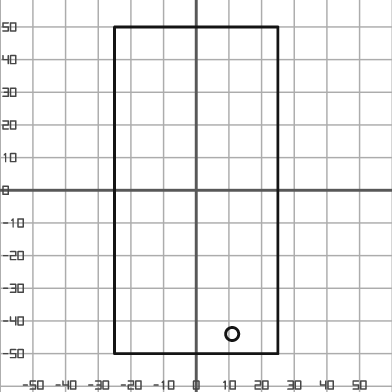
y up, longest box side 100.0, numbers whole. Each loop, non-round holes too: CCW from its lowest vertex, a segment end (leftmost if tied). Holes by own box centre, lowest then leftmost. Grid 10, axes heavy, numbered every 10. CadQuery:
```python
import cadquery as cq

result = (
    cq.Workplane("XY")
    .moveTo(-25.0, -50.0)
    .lineTo(25.0, -50.0)
    .lineTo(25.0, 50.0)
    .lineTo(-25.0, 50.0)
    .close()
    .moveTo(11.0, -44.0)
    .circle(2.0)
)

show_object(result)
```